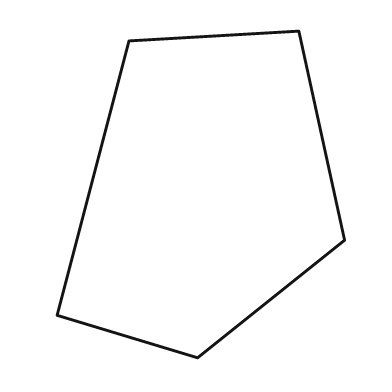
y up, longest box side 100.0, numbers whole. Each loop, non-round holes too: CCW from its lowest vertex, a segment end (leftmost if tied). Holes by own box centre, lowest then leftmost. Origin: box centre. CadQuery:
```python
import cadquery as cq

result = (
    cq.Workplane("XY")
    .moveTo(-1.0, -50.0)
    .lineTo(44.0, -14.0)
    .lineTo(30.0, 50.0)
    .lineTo(-22.0, 47.0)
    .lineTo(-44.0, -37.0)
    .close()
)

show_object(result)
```